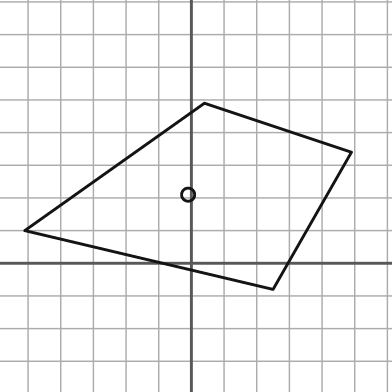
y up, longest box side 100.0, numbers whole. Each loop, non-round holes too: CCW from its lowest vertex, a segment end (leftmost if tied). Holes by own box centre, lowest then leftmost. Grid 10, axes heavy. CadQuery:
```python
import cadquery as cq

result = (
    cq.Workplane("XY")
    .moveTo(25.0, -8.0)
    .lineTo(49.0, 34.0)
    .lineTo(4.0, 49.0)
    .lineTo(-51.0, 10.0)
    .close()
    .moveTo(-1.0, 21.0)
    .circle(2.0)
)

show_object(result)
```